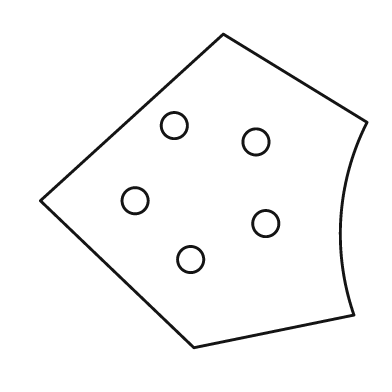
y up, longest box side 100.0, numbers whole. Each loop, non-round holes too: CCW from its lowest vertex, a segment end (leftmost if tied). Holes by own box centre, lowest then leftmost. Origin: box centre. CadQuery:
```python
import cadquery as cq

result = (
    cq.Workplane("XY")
    .moveTo(-3.0, -48.0)
    .lineTo(46.0, -38.0)
    .threePointArc((42.0, -8.0), (50.0, 21.0))
    .lineTo(6.0, 48.0)
    .lineTo(-50.0, -3.0)
    .close()
    .moveTo(-4.0, -21.0)
    .circle(4.0)
    .moveTo(19.0, -10.0)
    .circle(4.0)
    .moveTo(-21.0, -3.0)
    .circle(4.0)
    .moveTo(16.0, 15.0)
    .circle(4.0)
    .moveTo(-9.0, 20.0)
    .circle(4.0)
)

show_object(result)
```